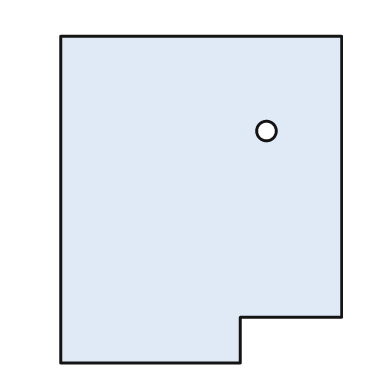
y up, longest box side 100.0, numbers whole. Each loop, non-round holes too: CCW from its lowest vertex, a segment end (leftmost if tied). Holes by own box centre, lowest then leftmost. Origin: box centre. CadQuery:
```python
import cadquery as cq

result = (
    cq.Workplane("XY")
    .moveTo(-43.0, -50.0)
    .lineTo(12.0, -50.0)
    .lineTo(12.0, -36.0)
    .lineTo(43.0, -36.0)
    .lineTo(43.0, 50.0)
    .lineTo(-43.0, 50.0)
    .close()
    .moveTo(20.0, 21.0)
    .circle(3.0)
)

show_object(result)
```